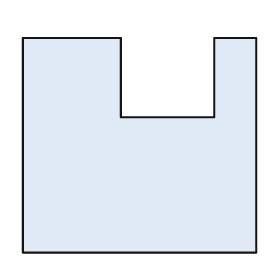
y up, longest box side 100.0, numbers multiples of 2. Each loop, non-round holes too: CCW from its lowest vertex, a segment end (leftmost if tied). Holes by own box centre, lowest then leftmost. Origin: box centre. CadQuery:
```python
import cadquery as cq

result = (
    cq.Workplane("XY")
    .moveTo(-50.0, -46.0)
    .lineTo(50.0, -46.0)
    .lineTo(50.0, 46.0)
    .lineTo(32.0, 46.0)
    .lineTo(32.0, 12.0)
    .lineTo(-8.0, 12.0)
    .lineTo(-8.0, 46.0)
    .lineTo(-50.0, 46.0)
    .close()
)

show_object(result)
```